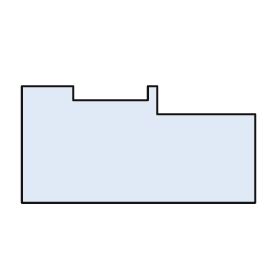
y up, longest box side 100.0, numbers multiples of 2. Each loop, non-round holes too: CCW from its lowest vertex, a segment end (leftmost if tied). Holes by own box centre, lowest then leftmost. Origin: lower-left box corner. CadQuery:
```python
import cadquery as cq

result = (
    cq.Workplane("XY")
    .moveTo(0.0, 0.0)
    .lineTo(100.0, 0.0)
    .lineTo(100.0, 38.0)
    .lineTo(58.0, 38.0)
    .lineTo(58.0, 50.0)
    .lineTo(54.0, 50.0)
    .lineTo(54.0, 44.0)
    .lineTo(22.0, 44.0)
    .lineTo(22.0, 50.0)
    .lineTo(0.0, 50.0)
    .close()
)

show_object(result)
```